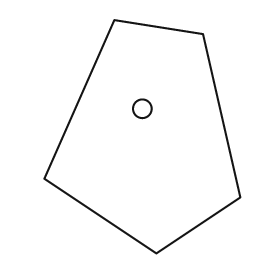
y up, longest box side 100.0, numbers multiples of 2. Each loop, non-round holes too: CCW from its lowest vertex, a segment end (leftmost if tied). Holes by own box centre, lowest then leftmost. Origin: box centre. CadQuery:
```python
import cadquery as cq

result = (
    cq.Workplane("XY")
    .moveTo(6.0, -50.0)
    .lineTo(42.0, -26.0)
    .lineTo(26.0, 44.0)
    .lineTo(-12.0, 50.0)
    .lineTo(-42.0, -18.0)
    .close()
    .moveTo(0.0, 12.0)
    .circle(4.0)
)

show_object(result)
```